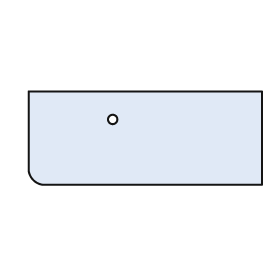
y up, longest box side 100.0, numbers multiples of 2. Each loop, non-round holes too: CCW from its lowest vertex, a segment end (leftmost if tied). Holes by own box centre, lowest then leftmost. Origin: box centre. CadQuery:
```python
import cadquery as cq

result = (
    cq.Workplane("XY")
    .moveTo(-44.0, -20.0)
    .lineTo(50.0, -20.0)
    .lineTo(50.0, 20.0)
    .lineTo(-50.0, 20.0)
    .lineTo(-50.0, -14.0)
    .threePointArc((-48.0, -18.0), (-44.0, -20.0))
    .close()
    .moveTo(-14.0, 8.0)
    .circle(2.0)
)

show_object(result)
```